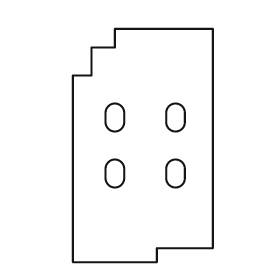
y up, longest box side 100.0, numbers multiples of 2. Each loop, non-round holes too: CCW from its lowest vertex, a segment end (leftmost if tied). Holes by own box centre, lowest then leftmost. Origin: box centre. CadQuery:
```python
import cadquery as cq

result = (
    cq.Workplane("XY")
    .moveTo(-30.0, -50.0)
    .lineTo(6.0, -50.0)
    .lineTo(6.0, -44.0)
    .lineTo(30.0, -44.0)
    .lineTo(30.0, 50.0)
    .lineTo(-12.0, 50.0)
    .lineTo(-12.0, 42.0)
    .lineTo(-22.0, 42.0)
    .lineTo(-22.0, 30.0)
    .lineTo(-30.0, 30.0)
    .close()
    .moveTo(-16.0, -14.0)
    .threePointArc((-12.0, -18.0), (-8.0, -14.0))
    .lineTo(-8.0, -10.0)
    .threePointArc((-12.0, -6.0), (-16.0, -10.0))
    .close()
    .moveTo(10.0, -14.0)
    .threePointArc((14.0, -18.0), (18.0, -14.0))
    .lineTo(18.0, -10.0)
    .threePointArc((14.0, -6.0), (10.0, -10.0))
    .close()
    .moveTo(-16.0, 10.0)
    .threePointArc((-12.0, 6.0), (-8.0, 10.0))
    .lineTo(-8.0, 14.0)
    .threePointArc((-12.0, 18.0), (-16.0, 14.0))
    .close()
    .moveTo(10.0, 10.0)
    .threePointArc((14.0, 6.0), (18.0, 10.0))
    .lineTo(18.0, 14.0)
    .threePointArc((14.0, 18.0), (10.0, 14.0))
    .close()
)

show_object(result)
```